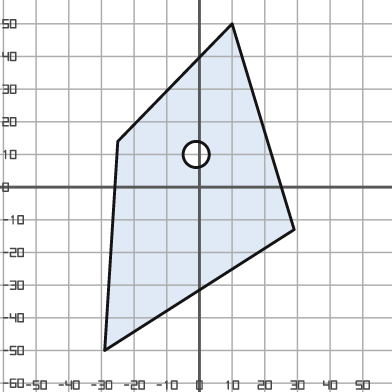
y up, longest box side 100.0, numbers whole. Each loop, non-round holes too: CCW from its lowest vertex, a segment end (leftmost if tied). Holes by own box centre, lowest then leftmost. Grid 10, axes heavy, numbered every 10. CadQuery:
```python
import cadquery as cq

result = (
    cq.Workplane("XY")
    .moveTo(-29.0, -50.0)
    .lineTo(29.0, -13.0)
    .lineTo(10.0, 50.0)
    .lineTo(-25.0, 14.0)
    .close()
    .moveTo(-1.0, 10.0)
    .circle(4.0)
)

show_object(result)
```